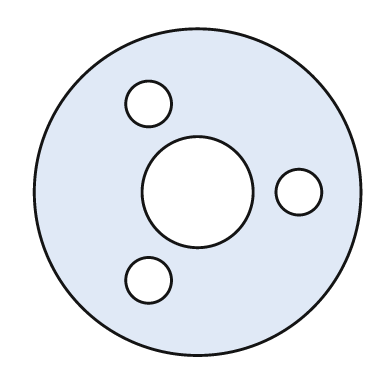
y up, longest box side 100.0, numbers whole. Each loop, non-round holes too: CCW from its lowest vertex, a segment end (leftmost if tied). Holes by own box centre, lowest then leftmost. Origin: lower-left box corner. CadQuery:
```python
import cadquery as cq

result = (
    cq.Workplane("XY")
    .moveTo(50.0, 50.0)
    .circle(50.0)
    .moveTo(35.0, 23.0)
    .circle(7.0)
    .moveTo(50.0, 50.0)
    .circle(17.0)
    .moveTo(81.0, 50.0)
    .circle(7.0)
    .moveTo(35.0, 77.0)
    .circle(7.0)
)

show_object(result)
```